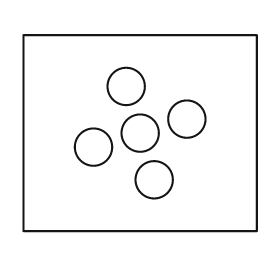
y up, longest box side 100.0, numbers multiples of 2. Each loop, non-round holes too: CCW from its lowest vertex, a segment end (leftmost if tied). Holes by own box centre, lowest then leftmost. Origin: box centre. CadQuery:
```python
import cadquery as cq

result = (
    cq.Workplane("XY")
    .moveTo(-50.0, -42.0)
    .lineTo(50.0, -42.0)
    .lineTo(50.0, 42.0)
    .lineTo(-50.0, 42.0)
    .close()
    .moveTo(6.0, -20.0)
    .circle(8.0)
    .moveTo(-20.0, -6.0)
    .circle(8.0)
    .moveTo(0.0, 0.0)
    .circle(8.0)
    .moveTo(20.0, 6.0)
    .circle(8.0)
    .moveTo(-6.0, 20.0)
    .circle(8.0)
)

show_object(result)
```